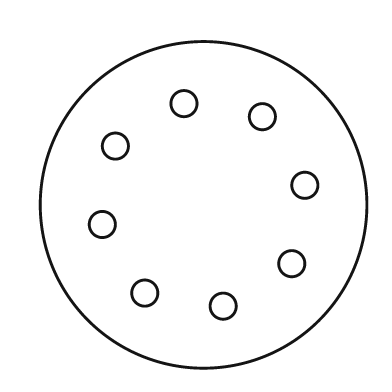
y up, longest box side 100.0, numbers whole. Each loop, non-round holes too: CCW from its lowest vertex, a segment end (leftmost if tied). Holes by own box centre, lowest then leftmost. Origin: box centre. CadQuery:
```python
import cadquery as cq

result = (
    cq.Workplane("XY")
    .moveTo(0.0, 0.0)
    .circle(50.0)
    .moveTo(6.0, -31.0)
    .circle(4.0)
    .moveTo(-18.0, -27.0)
    .circle(4.0)
    .moveTo(27.0, -18.0)
    .circle(4.0)
    .moveTo(-31.0, -6.0)
    .circle(4.0)
    .moveTo(31.0, 6.0)
    .circle(4.0)
    .moveTo(-27.0, 18.0)
    .circle(4.0)
    .moveTo(18.0, 27.0)
    .circle(4.0)
    .moveTo(-6.0, 31.0)
    .circle(4.0)
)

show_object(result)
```